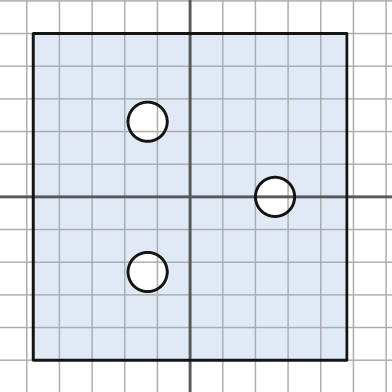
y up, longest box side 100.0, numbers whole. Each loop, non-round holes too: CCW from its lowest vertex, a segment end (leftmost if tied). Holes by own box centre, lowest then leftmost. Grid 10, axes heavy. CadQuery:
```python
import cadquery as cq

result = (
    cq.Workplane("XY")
    .moveTo(-48.0, -50.0)
    .lineTo(48.0, -50.0)
    .lineTo(48.0, 50.0)
    .lineTo(-48.0, 50.0)
    .close()
    .moveTo(-13.0, -23.0)
    .circle(6.0)
    .moveTo(26.0, 0.0)
    .circle(6.0)
    .moveTo(-13.0, 23.0)
    .circle(6.0)
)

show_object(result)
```